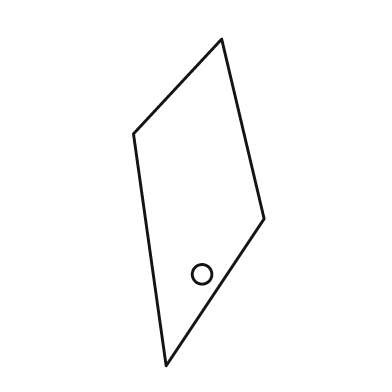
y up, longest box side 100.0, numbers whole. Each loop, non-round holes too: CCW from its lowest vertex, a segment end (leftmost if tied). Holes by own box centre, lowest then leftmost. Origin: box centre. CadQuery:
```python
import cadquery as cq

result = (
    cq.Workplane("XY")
    .moveTo(-10.0, -50.0)
    .lineTo(20.0, -5.0)
    .lineTo(7.0, 50.0)
    .lineTo(-20.0, 21.0)
    .close()
    .moveTo(1.0, -22.0)
    .circle(3.0)
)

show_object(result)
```